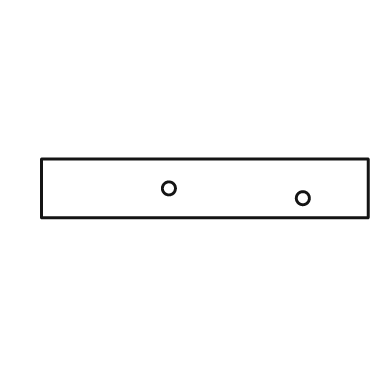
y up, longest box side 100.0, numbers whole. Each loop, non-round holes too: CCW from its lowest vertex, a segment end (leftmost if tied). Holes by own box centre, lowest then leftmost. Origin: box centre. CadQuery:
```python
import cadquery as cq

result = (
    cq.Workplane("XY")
    .moveTo(-50.0, -9.0)
    .lineTo(50.0, -9.0)
    .lineTo(50.0, 9.0)
    .lineTo(-50.0, 9.0)
    .close()
    .moveTo(30.0, -3.0)
    .circle(2.0)
    .moveTo(-11.0, 0.0)
    .circle(2.0)
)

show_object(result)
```